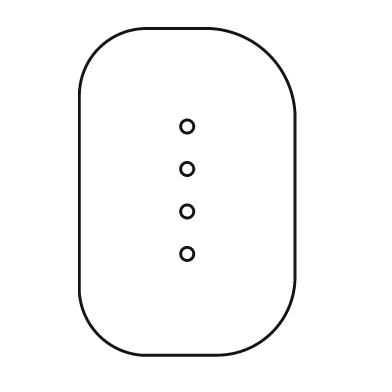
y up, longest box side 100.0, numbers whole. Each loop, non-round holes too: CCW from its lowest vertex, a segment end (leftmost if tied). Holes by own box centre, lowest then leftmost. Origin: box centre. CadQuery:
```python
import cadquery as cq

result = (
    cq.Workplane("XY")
    .moveTo(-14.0, -50.0)
    .lineTo(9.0, -50.0)
    .threePointArc((26.0, -43.0), (33.0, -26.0))
    .lineTo(33.0, 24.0)
    .threePointArc((25.0, 42.0), (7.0, 50.0))
    .lineTo(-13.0, 50.0)
    .threePointArc((-27.0, 44.0), (-33.0, 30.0))
    .lineTo(-33.0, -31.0)
    .threePointArc((-27.0, -44.0), (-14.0, -50.0))
    .close()
    .moveTo(0.0, -19.0)
    .circle(2.0)
    .moveTo(0.0, -6.0)
    .circle(2.0)
    .moveTo(0.0, 7.0)
    .circle(2.0)
    .moveTo(0.0, 20.0)
    .circle(2.0)
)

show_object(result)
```